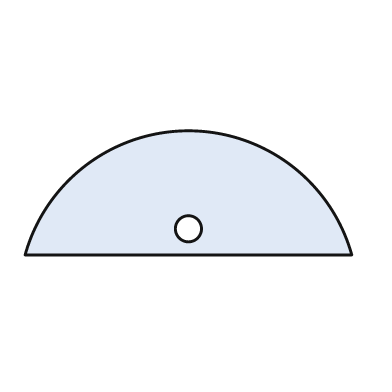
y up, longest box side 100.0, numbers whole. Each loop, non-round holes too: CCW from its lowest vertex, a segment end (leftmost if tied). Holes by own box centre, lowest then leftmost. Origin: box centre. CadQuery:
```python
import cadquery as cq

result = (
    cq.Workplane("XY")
    .moveTo(-50.0, -19.0)
    .lineTo(50.0, -19.0)
    .threePointArc((0.0, 19.0), (-50.0, -19.0))
    .close()
    .moveTo(0.0, -11.0)
    .circle(4.0)
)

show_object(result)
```